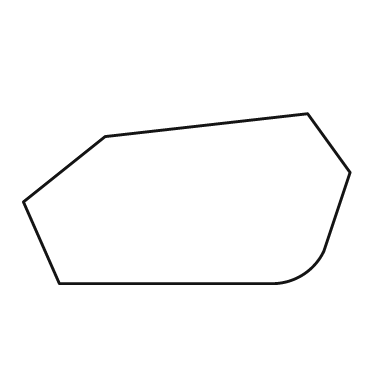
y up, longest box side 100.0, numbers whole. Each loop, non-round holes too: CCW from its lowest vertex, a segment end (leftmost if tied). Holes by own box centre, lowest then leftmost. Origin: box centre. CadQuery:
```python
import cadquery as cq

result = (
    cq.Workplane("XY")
    .moveTo(-39.0, -26.0)
    .lineTo(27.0, -26.0)
    .threePointArc((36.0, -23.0), (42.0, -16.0))
    .lineTo(50.0, 8.0)
    .lineTo(37.0, 26.0)
    .lineTo(-25.0, 19.0)
    .lineTo(-50.0, -1.0)
    .close()
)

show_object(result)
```